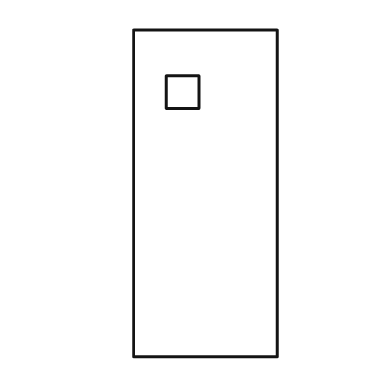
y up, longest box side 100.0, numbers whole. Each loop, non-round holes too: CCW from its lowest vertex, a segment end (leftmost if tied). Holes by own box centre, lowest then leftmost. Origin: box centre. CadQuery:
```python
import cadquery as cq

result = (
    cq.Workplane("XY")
    .moveTo(-22.0, -50.0)
    .lineTo(22.0, -50.0)
    .lineTo(22.0, 50.0)
    .lineTo(-22.0, 50.0)
    .close()
    .moveTo(-12.0, 26.0)
    .lineTo(-2.0, 26.0)
    .lineTo(-2.0, 36.0)
    .lineTo(-12.0, 36.0)
    .close()
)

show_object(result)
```